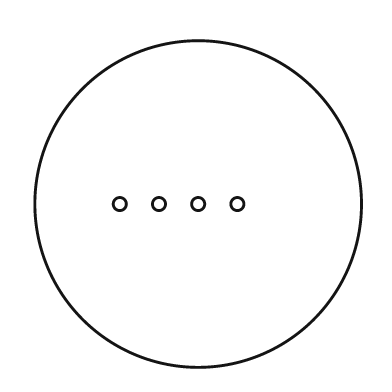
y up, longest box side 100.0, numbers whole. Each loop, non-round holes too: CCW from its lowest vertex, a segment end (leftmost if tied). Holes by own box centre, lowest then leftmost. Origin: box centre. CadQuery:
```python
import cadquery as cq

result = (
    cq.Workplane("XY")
    .moveTo(0.0, 0.0)
    .circle(50.0)
    .moveTo(-24.0, 0.0)
    .circle(2.0)
    .moveTo(-12.0, 0.0)
    .circle(2.0)
    .moveTo(0.0, 0.0)
    .circle(2.0)
    .moveTo(12.0, 0.0)
    .circle(2.0)
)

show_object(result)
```